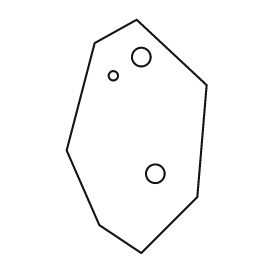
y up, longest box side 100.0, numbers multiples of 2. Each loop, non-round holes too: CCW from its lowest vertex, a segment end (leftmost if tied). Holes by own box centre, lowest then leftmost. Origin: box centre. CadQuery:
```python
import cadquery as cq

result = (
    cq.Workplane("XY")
    .moveTo(2.0, -50.0)
    .lineTo(26.0, -26.0)
    .lineTo(30.0, 22.0)
    .lineTo(0.0, 50.0)
    .lineTo(-18.0, 40.0)
    .lineTo(-30.0, -6.0)
    .lineTo(-16.0, -38.0)
    .close()
    .moveTo(8.0, -16.0)
    .circle(4.0)
    .moveTo(-10.0, 26.0)
    .circle(2.0)
    .moveTo(2.0, 34.0)
    .circle(4.0)
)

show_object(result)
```